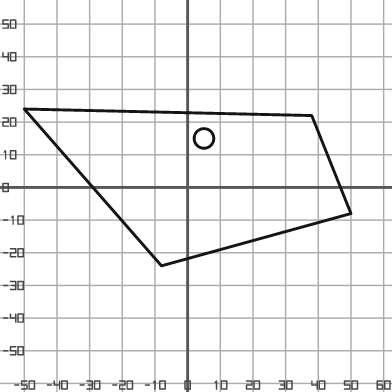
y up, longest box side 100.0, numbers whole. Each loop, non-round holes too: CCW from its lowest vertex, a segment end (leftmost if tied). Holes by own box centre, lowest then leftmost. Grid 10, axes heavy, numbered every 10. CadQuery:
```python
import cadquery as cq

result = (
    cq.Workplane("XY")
    .moveTo(-8.0, -24.0)
    .lineTo(50.0, -8.0)
    .lineTo(38.0, 22.0)
    .lineTo(-50.0, 24.0)
    .close()
    .moveTo(5.0, 15.0)
    .circle(3.0)
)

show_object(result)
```